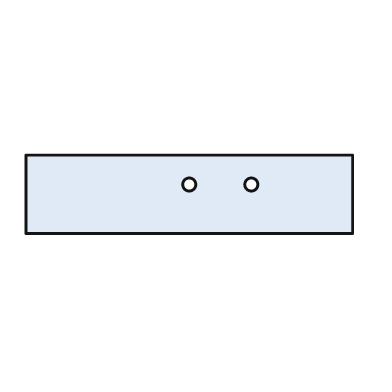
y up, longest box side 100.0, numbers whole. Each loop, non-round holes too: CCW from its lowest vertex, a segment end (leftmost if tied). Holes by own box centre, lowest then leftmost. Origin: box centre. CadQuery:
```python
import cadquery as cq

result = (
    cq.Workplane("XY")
    .moveTo(-50.0, -12.0)
    .lineTo(50.0, -12.0)
    .lineTo(50.0, 12.0)
    .lineTo(-50.0, 12.0)
    .close()
    .moveTo(0.0, 3.0)
    .circle(2.0)
    .moveTo(19.0, 3.0)
    .circle(2.0)
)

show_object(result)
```